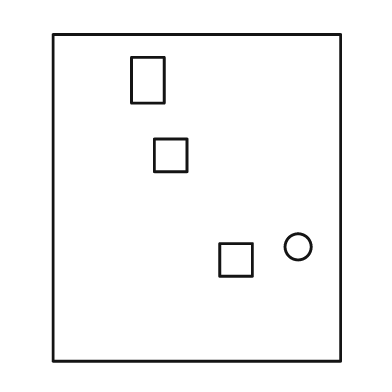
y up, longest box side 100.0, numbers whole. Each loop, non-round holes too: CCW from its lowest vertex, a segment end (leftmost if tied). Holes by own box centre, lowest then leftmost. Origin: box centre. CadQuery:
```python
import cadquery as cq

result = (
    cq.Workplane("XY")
    .moveTo(-44.0, -50.0)
    .lineTo(44.0, -50.0)
    .lineTo(44.0, 50.0)
    .lineTo(-44.0, 50.0)
    .close()
    .moveTo(7.0, -24.0)
    .lineTo(17.0, -24.0)
    .lineTo(17.0, -14.0)
    .lineTo(7.0, -14.0)
    .close()
    .moveTo(31.0, -15.0)
    .circle(4.0)
    .moveTo(-13.0, 8.0)
    .lineTo(-3.0, 8.0)
    .lineTo(-3.0, 18.0)
    .lineTo(-13.0, 18.0)
    .close()
    .moveTo(-20.0, 29.0)
    .lineTo(-10.0, 29.0)
    .lineTo(-10.0, 43.0)
    .lineTo(-20.0, 43.0)
    .close()
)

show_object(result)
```